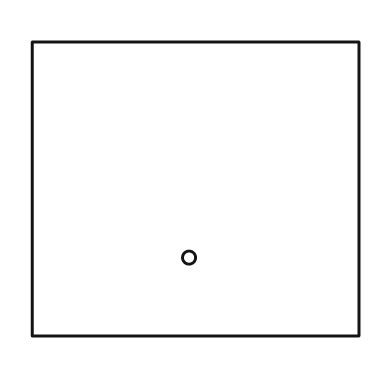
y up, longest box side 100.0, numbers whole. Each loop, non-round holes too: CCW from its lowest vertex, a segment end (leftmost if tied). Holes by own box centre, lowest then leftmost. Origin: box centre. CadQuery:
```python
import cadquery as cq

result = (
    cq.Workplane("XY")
    .moveTo(-50.0, -45.0)
    .lineTo(50.0, -45.0)
    .lineTo(50.0, 45.0)
    .lineTo(-50.0, 45.0)
    .close()
    .moveTo(-2.0, -21.0)
    .circle(2.0)
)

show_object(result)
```